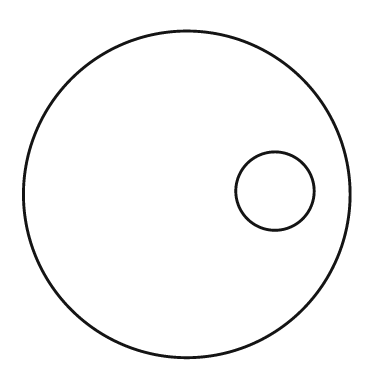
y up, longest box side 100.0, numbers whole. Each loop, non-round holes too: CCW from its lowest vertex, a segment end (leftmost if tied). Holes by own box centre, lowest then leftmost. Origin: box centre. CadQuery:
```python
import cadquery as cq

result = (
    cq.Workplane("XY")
    .moveTo(0.0, 0.0)
    .circle(50.0)
    .moveTo(27.0, 1.0)
    .circle(12.0)
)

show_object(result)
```